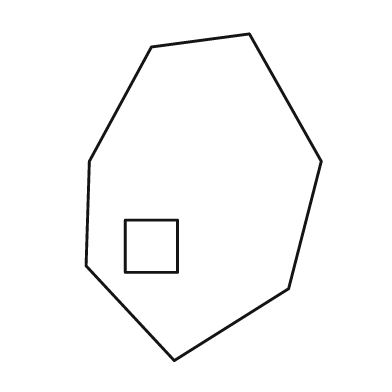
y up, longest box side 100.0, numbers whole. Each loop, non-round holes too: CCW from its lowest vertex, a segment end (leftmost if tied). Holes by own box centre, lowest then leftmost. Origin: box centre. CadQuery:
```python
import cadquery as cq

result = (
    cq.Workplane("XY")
    .moveTo(-9.0, -50.0)
    .lineTo(26.0, -28.0)
    .lineTo(36.0, 11.0)
    .lineTo(14.0, 50.0)
    .lineTo(-16.0, 46.0)
    .lineTo(-35.0, 11.0)
    .lineTo(-36.0, -21.0)
    .close()
    .moveTo(-24.0, -23.0)
    .lineTo(-8.0, -23.0)
    .lineTo(-8.0, -7.0)
    .lineTo(-24.0, -7.0)
    .close()
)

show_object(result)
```